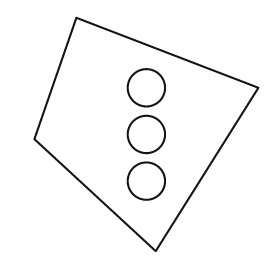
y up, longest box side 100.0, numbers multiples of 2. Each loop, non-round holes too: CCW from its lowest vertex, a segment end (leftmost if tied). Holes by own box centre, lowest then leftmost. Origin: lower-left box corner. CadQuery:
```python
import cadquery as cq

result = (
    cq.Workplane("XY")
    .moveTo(52.0, 0.0)
    .lineTo(96.0, 70.0)
    .lineTo(18.0, 100.0)
    .lineTo(0.0, 48.0)
    .close()
    .moveTo(48.0, 30.0)
    .circle(8.0)
    .moveTo(48.0, 50.0)
    .circle(8.0)
    .moveTo(48.0, 70.0)
    .circle(8.0)
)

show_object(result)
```